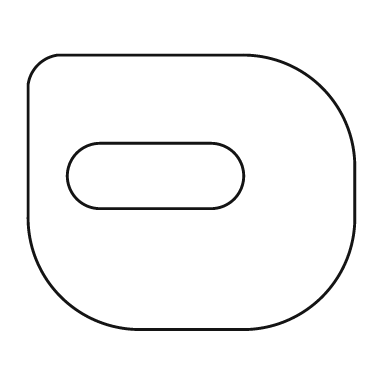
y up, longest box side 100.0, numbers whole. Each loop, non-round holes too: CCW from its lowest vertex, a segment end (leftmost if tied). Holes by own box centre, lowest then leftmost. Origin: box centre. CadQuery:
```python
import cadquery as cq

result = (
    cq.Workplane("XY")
    .moveTo(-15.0, -42.0)
    .lineTo(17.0, -42.0)
    .threePointArc((40.0, -32.0), (50.0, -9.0))
    .lineTo(50.0, 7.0)
    .threePointArc((40.0, 32.0), (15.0, 42.0))
    .lineTo(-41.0, 42.0)
    .threePointArc((-47.0, 39.0), (-50.0, 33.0))
    .lineTo(-50.0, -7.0)
    .threePointArc((-40.0, -32.0), (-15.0, -42.0))
    .close()
    .moveTo(-28.0, -5.0)
    .lineTo(6.0, -5.0)
    .threePointArc((16.0, 5.0), (6.0, 15.0))
    .lineTo(-28.0, 15.0)
    .threePointArc((-38.0, 5.0), (-28.0, -5.0))
    .close()
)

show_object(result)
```